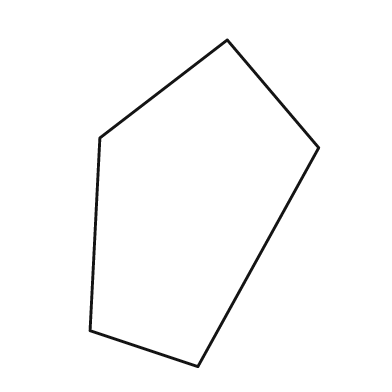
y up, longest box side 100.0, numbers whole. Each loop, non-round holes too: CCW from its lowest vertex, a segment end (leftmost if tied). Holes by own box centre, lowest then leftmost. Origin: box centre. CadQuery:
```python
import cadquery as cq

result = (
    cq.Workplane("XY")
    .moveTo(-2.0, -50.0)
    .lineTo(35.0, 17.0)
    .lineTo(7.0, 50.0)
    .lineTo(-32.0, 20.0)
    .lineTo(-35.0, -39.0)
    .close()
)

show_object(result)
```